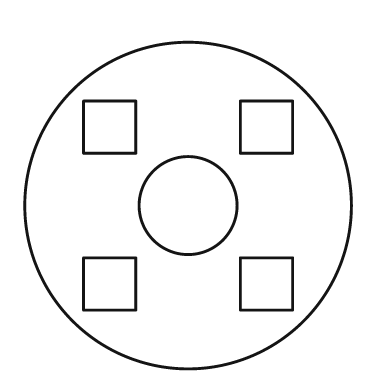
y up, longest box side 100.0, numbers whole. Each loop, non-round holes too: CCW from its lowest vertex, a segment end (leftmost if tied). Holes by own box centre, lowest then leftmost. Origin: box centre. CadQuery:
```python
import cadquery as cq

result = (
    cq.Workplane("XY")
    .moveTo(0.0, 0.0)
    .circle(50.0)
    .moveTo(-32.0, -32.0)
    .lineTo(-16.0, -32.0)
    .lineTo(-16.0, -16.0)
    .lineTo(-32.0, -16.0)
    .close()
    .moveTo(16.0, -32.0)
    .lineTo(32.0, -32.0)
    .lineTo(32.0, -16.0)
    .lineTo(16.0, -16.0)
    .close()
    .moveTo(0.0, 0.0)
    .circle(15.0)
    .moveTo(-32.0, 16.0)
    .lineTo(-16.0, 16.0)
    .lineTo(-16.0, 32.0)
    .lineTo(-32.0, 32.0)
    .close()
    .moveTo(16.0, 16.0)
    .lineTo(32.0, 16.0)
    .lineTo(32.0, 32.0)
    .lineTo(16.0, 32.0)
    .close()
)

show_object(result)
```